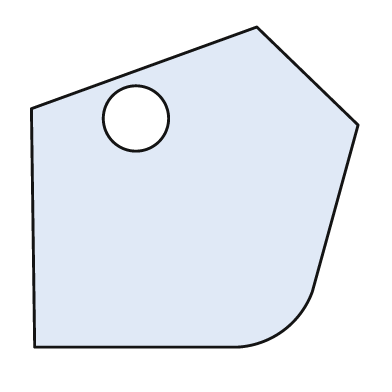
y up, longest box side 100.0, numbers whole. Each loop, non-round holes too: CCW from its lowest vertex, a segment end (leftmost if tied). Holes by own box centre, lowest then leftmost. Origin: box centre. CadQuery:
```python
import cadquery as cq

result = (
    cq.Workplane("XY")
    .moveTo(-49.0, -49.0)
    .lineTo(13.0, -49.0)
    .threePointArc((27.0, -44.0), (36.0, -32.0))
    .lineTo(50.0, 19.0)
    .lineTo(19.0, 49.0)
    .lineTo(-50.0, 24.0)
    .close()
    .moveTo(-18.0, 21.0)
    .circle(10.0)
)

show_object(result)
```